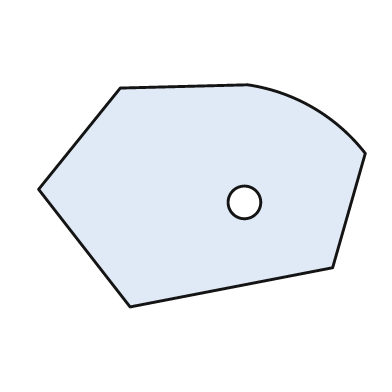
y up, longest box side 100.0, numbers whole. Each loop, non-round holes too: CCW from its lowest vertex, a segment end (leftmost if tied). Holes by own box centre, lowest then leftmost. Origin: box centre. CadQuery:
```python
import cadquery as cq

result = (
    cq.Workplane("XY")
    .moveTo(-22.0, -34.0)
    .lineTo(40.0, -22.0)
    .lineTo(50.0, 13.0)
    .threePointArc((34.0, 27.0), (14.0, 34.0))
    .lineTo(-25.0, 33.0)
    .lineTo(-50.0, 2.0)
    .close()
    .moveTo(13.0, -2.0)
    .circle(5.0)
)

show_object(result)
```